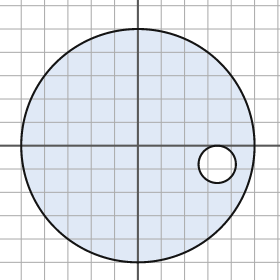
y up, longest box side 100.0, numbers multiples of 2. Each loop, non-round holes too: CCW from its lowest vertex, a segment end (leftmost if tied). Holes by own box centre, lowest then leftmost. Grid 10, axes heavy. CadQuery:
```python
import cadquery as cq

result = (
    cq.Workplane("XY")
    .moveTo(0.0, 0.0)
    .circle(50.0)
    .moveTo(34.0, -8.0)
    .circle(8.0)
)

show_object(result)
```